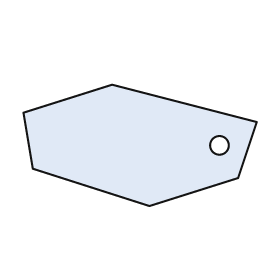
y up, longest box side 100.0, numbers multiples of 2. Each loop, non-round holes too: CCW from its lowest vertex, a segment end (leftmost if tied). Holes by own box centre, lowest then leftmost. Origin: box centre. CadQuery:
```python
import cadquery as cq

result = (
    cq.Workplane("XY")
    .moveTo(4.0, -26.0)
    .lineTo(42.0, -14.0)
    .lineTo(50.0, 10.0)
    .lineTo(-12.0, 26.0)
    .lineTo(-50.0, 14.0)
    .lineTo(-46.0, -10.0)
    .close()
    .moveTo(34.0, 0.0)
    .circle(4.0)
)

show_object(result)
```